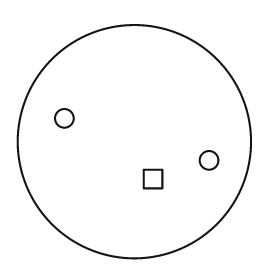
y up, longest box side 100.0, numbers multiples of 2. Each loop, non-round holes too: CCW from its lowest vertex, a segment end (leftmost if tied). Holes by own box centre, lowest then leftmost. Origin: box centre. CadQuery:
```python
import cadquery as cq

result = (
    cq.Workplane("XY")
    .moveTo(0.0, 0.0)
    .circle(50.0)
    .moveTo(4.0, -20.0)
    .lineTo(12.0, -20.0)
    .lineTo(12.0, -12.0)
    .lineTo(4.0, -12.0)
    .close()
    .moveTo(32.0, -8.0)
    .circle(4.0)
    .moveTo(-30.0, 10.0)
    .circle(4.0)
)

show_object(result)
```